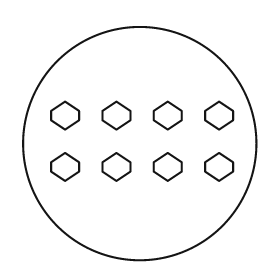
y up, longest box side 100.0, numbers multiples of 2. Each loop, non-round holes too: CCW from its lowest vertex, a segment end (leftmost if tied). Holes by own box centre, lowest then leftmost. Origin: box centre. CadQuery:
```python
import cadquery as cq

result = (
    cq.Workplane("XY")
    .moveTo(0.0, 0.0)
    .circle(50.0)
    .moveTo(-32.0, -16.0)
    .lineTo(-26.0, -12.0)
    .lineTo(-26.0, -8.0)
    .lineTo(-32.0, -4.0)
    .lineTo(-38.0, -8.0)
    .lineTo(-38.0, -12.0)
    .close()
    .moveTo(-10.0, -16.0)
    .lineTo(-4.0, -12.0)
    .lineTo(-4.0, -8.0)
    .lineTo(-10.0, -4.0)
    .lineTo(-16.0, -8.0)
    .lineTo(-16.0, -12.0)
    .close()
    .moveTo(12.0, -16.0)
    .lineTo(18.0, -12.0)
    .lineTo(18.0, -8.0)
    .lineTo(12.0, -4.0)
    .lineTo(6.0, -8.0)
    .lineTo(6.0, -12.0)
    .close()
    .moveTo(34.0, -16.0)
    .lineTo(40.0, -12.0)
    .lineTo(40.0, -8.0)
    .lineTo(34.0, -4.0)
    .lineTo(28.0, -8.0)
    .lineTo(28.0, -12.0)
    .close()
    .moveTo(-32.0, 6.0)
    .lineTo(-26.0, 10.0)
    .lineTo(-26.0, 14.0)
    .lineTo(-32.0, 18.0)
    .lineTo(-38.0, 14.0)
    .lineTo(-38.0, 10.0)
    .close()
    .moveTo(-10.0, 6.0)
    .lineTo(-4.0, 10.0)
    .lineTo(-4.0, 14.0)
    .lineTo(-10.0, 18.0)
    .lineTo(-16.0, 14.0)
    .lineTo(-16.0, 10.0)
    .close()
    .moveTo(12.0, 6.0)
    .lineTo(18.0, 10.0)
    .lineTo(18.0, 14.0)
    .lineTo(12.0, 18.0)
    .lineTo(6.0, 14.0)
    .lineTo(6.0, 10.0)
    .close()
    .moveTo(34.0, 6.0)
    .lineTo(40.0, 10.0)
    .lineTo(40.0, 14.0)
    .lineTo(34.0, 18.0)
    .lineTo(28.0, 14.0)
    .lineTo(28.0, 10.0)
    .close()
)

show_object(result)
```